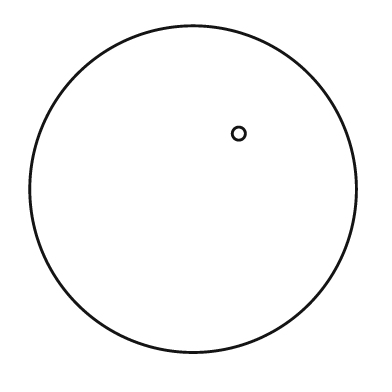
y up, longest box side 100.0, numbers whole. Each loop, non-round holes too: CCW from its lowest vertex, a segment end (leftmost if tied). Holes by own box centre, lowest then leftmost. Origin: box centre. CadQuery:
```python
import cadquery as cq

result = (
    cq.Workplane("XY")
    .moveTo(0.0, 0.0)
    .circle(50.0)
    .moveTo(14.0, 17.0)
    .circle(2.0)
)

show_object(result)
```